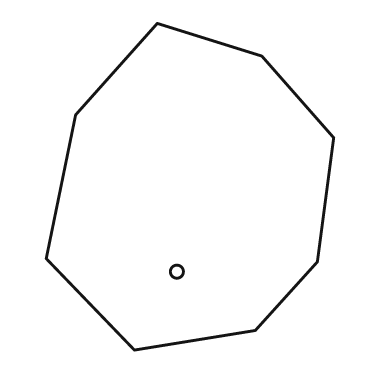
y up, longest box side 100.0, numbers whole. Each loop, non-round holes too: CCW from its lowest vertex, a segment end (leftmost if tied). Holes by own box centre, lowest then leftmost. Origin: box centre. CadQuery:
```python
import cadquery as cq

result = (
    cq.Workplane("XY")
    .moveTo(-17.0, -50.0)
    .lineTo(20.0, -44.0)
    .lineTo(39.0, -23.0)
    .lineTo(44.0, 15.0)
    .lineTo(22.0, 40.0)
    .lineTo(-10.0, 50.0)
    .lineTo(-35.0, 22.0)
    .lineTo(-44.0, -22.0)
    .close()
    .moveTo(-4.0, -26.0)
    .circle(2.0)
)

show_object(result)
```